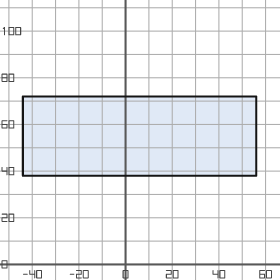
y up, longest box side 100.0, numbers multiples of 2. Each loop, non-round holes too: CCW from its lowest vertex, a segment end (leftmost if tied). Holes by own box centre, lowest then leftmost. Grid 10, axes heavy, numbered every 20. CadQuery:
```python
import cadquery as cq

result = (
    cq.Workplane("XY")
    .moveTo(-44.0, 38.0)
    .lineTo(56.0, 38.0)
    .lineTo(56.0, 72.0)
    .lineTo(-44.0, 72.0)
    .close()
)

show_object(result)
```